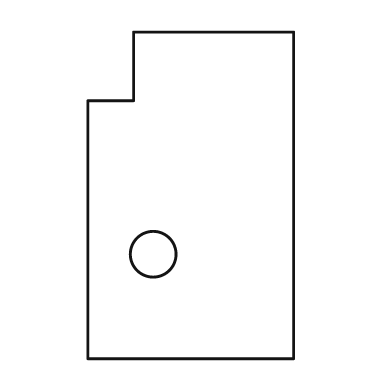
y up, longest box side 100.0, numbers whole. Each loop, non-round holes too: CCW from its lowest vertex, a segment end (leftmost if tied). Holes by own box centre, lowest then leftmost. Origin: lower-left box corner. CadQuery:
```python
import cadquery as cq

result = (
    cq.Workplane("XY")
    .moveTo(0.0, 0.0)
    .lineTo(63.0, 0.0)
    .lineTo(63.0, 100.0)
    .lineTo(14.0, 100.0)
    .lineTo(14.0, 79.0)
    .lineTo(0.0, 79.0)
    .close()
    .moveTo(20.0, 32.0)
    .circle(7.0)
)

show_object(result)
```